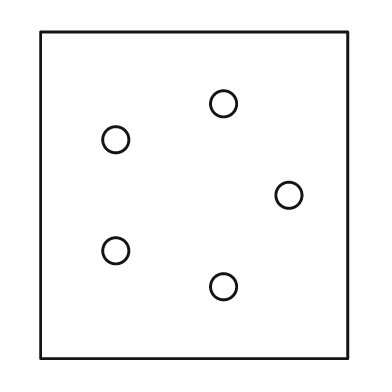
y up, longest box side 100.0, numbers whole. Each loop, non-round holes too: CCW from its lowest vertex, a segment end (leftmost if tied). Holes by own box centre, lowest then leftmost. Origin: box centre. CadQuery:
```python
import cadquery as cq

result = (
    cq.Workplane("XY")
    .moveTo(-47.0, -50.0)
    .lineTo(47.0, -50.0)
    .lineTo(47.0, 50.0)
    .lineTo(-47.0, 50.0)
    .close()
    .moveTo(9.0, -28.0)
    .circle(4.0)
    .moveTo(-24.0, -17.0)
    .circle(4.0)
    .moveTo(29.0, 0.0)
    .circle(4.0)
    .moveTo(-24.0, 17.0)
    .circle(4.0)
    .moveTo(9.0, 28.0)
    .circle(4.0)
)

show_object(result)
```